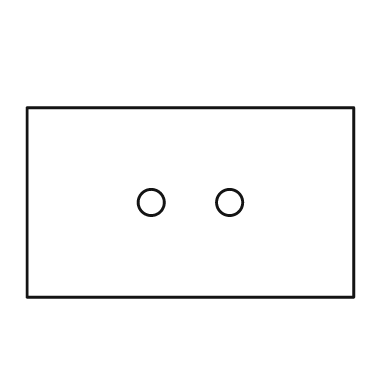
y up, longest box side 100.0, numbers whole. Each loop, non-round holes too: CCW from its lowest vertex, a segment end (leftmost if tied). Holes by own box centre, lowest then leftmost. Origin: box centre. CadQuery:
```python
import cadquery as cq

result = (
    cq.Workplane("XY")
    .moveTo(-50.0, -29.0)
    .lineTo(50.0, -29.0)
    .lineTo(50.0, 29.0)
    .lineTo(-50.0, 29.0)
    .close()
    .moveTo(-12.0, 0.0)
    .circle(4.0)
    .moveTo(12.0, 0.0)
    .circle(4.0)
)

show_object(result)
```